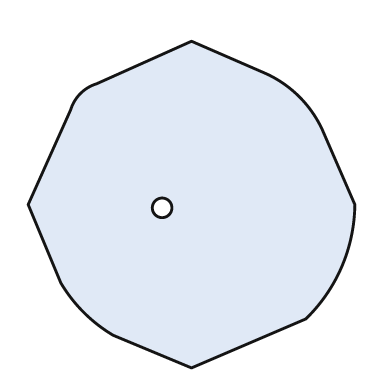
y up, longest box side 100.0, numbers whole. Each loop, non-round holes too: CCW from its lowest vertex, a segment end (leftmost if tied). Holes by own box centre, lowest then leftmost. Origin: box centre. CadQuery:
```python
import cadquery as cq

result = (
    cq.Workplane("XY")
    .moveTo(0.0, -50.0)
    .lineTo(35.0, -35.0)
    .threePointArc((46.0, -19.0), (50.0, 0.0))
    .lineTo(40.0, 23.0)
    .threePointArc((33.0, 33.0), (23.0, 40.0))
    .lineTo(0.0, 50.0)
    .lineTo(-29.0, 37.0)
    .threePointArc((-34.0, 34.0), (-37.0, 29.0))
    .lineTo(-50.0, 0.0)
    .lineTo(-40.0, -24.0)
    .threePointArc((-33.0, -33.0), (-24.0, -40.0))
    .close()
    .moveTo(-9.0, -1.0)
    .circle(3.0)
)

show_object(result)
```